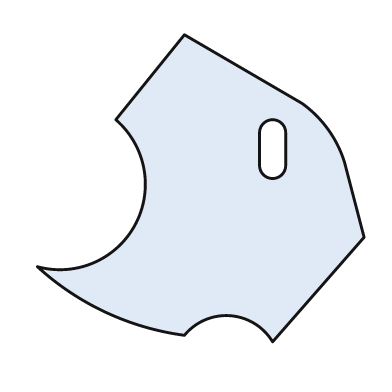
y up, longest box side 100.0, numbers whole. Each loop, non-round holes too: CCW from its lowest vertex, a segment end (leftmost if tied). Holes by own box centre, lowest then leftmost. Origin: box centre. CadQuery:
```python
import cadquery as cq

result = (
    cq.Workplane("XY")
    .moveTo(22.0, -47.0)
    .lineTo(50.0, -15.0)
    .lineTo(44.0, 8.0)
    .threePointArc((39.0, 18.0), (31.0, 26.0))
    .lineTo(-5.0, 47.0)
    .lineTo(-26.0, 21.0)
    .threePointArc((-20.0, -11.0), (-50.0, -24.0))
    .threePointArc((-29.0, -38.0), (-5.0, -45.0))
    .threePointArc((9.0, -39.0), (22.0, -47.0))
    .close()
    .moveTo(18.0, 7.0)
    .threePointArc((22.0, 3.0), (26.0, 7.0))
    .lineTo(26.0, 17.0)
    .threePointArc((22.0, 21.0), (18.0, 17.0))
    .close()
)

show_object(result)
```